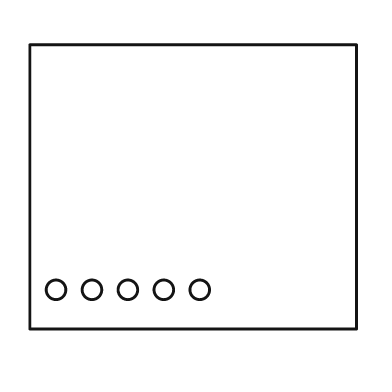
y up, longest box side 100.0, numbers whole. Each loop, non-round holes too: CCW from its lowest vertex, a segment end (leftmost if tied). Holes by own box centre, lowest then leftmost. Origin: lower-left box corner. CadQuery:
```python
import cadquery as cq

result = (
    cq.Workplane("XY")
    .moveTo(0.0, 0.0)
    .lineTo(100.0, 0.0)
    .lineTo(100.0, 87.0)
    .lineTo(0.0, 87.0)
    .close()
    .moveTo(8.0, 12.0)
    .circle(3.0)
    .moveTo(19.0, 12.0)
    .circle(3.0)
    .moveTo(30.0, 12.0)
    .circle(3.0)
    .moveTo(41.0, 12.0)
    .circle(3.0)
    .moveTo(52.0, 12.0)
    .circle(3.0)
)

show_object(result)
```